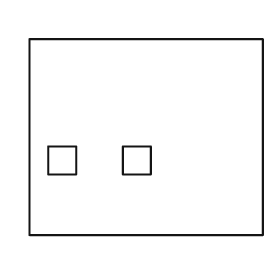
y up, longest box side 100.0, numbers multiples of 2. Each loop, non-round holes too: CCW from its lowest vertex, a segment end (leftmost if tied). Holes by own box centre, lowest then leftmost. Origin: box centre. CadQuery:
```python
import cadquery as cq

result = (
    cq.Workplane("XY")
    .moveTo(-50.0, -42.0)
    .lineTo(50.0, -42.0)
    .lineTo(50.0, 42.0)
    .lineTo(-50.0, 42.0)
    .close()
    .moveTo(-42.0, -16.0)
    .lineTo(-30.0, -16.0)
    .lineTo(-30.0, -4.0)
    .lineTo(-42.0, -4.0)
    .close()
    .moveTo(-10.0, -16.0)
    .lineTo(2.0, -16.0)
    .lineTo(2.0, -4.0)
    .lineTo(-10.0, -4.0)
    .close()
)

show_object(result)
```